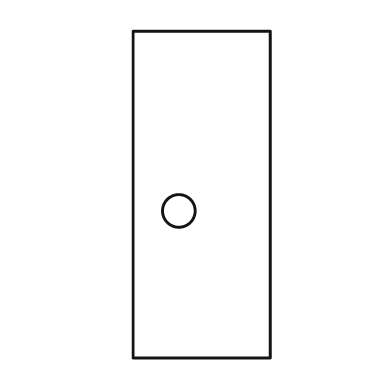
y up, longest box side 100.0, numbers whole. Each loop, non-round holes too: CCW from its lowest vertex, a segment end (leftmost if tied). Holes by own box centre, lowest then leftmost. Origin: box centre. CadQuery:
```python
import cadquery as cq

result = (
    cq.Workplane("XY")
    .moveTo(-21.0, -50.0)
    .lineTo(21.0, -50.0)
    .lineTo(21.0, 50.0)
    .lineTo(-21.0, 50.0)
    .close()
    .moveTo(-7.0, -5.0)
    .circle(5.0)
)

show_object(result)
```